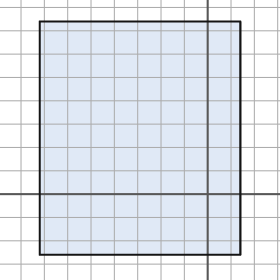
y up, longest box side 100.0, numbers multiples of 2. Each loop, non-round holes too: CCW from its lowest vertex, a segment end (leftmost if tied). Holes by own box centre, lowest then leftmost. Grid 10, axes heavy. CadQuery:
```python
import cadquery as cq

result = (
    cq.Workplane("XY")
    .moveTo(-72.0, -26.0)
    .lineTo(14.0, -26.0)
    .lineTo(14.0, 74.0)
    .lineTo(-72.0, 74.0)
    .close()
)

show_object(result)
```